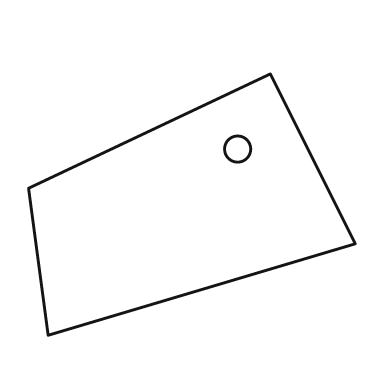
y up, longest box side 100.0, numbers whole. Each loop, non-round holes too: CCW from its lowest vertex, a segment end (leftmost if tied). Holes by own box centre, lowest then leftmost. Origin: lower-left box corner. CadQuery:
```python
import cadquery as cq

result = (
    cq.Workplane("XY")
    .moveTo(6.0, 0.0)
    .lineTo(100.0, 28.0)
    .lineTo(74.0, 80.0)
    .lineTo(0.0, 45.0)
    .close()
    .moveTo(64.0, 57.0)
    .circle(4.0)
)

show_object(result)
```